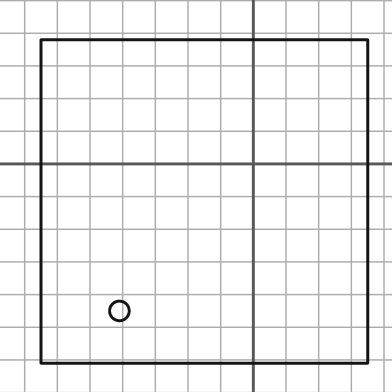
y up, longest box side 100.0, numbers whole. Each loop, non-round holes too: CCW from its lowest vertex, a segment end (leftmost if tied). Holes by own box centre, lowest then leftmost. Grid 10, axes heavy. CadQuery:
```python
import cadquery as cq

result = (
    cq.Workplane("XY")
    .moveTo(-65.0, -61.0)
    .lineTo(35.0, -61.0)
    .lineTo(35.0, 38.0)
    .lineTo(-65.0, 38.0)
    .close()
    .moveTo(-41.0, -45.0)
    .circle(3.0)
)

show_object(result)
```